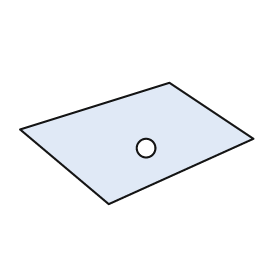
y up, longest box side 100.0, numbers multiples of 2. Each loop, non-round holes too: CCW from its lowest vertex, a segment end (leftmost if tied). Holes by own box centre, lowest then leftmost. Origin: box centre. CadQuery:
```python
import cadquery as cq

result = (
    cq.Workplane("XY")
    .moveTo(-12.0, -26.0)
    .lineTo(50.0, 2.0)
    .lineTo(14.0, 26.0)
    .lineTo(-50.0, 6.0)
    .close()
    .moveTo(4.0, -2.0)
    .circle(4.0)
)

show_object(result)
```